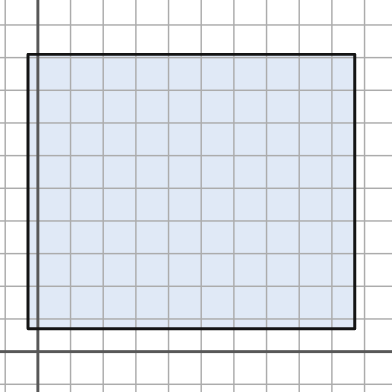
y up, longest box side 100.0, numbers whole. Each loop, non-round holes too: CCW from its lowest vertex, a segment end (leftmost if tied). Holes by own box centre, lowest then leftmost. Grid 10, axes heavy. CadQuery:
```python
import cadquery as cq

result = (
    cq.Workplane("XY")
    .moveTo(-3.0, 7.0)
    .lineTo(97.0, 7.0)
    .lineTo(97.0, 91.0)
    .lineTo(-3.0, 91.0)
    .close()
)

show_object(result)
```